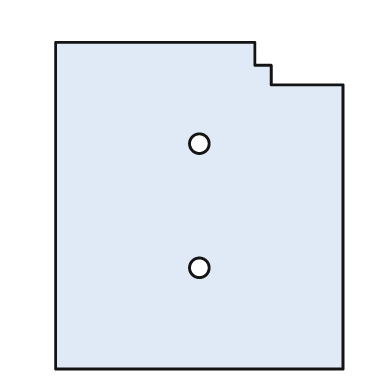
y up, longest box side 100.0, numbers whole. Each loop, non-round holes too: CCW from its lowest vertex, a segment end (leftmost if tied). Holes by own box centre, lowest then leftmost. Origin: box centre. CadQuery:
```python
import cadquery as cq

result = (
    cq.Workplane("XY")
    .moveTo(-44.0, -50.0)
    .lineTo(44.0, -50.0)
    .lineTo(44.0, 37.0)
    .lineTo(22.0, 37.0)
    .lineTo(22.0, 43.0)
    .lineTo(17.0, 43.0)
    .lineTo(17.0, 50.0)
    .lineTo(-44.0, 50.0)
    .close()
    .moveTo(0.0, -19.0)
    .circle(3.0)
    .moveTo(0.0, 19.0)
    .circle(3.0)
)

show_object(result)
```